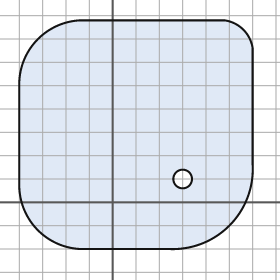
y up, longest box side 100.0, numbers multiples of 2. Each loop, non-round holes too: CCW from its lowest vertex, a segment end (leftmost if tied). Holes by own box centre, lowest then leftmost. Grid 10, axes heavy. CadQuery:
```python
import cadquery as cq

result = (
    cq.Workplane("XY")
    .moveTo(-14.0, -20.0)
    .lineTo(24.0, -20.0)
    .threePointArc((50.0, -10.0), (60.0, 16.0))
    .lineTo(60.0, 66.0)
    .threePointArc((56.0, 74.0), (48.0, 78.0))
    .lineTo(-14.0, 78.0)
    .threePointArc((-32.0, 70.0), (-40.0, 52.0))
    .lineTo(-40.0, 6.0)
    .threePointArc((-32.0, -12.0), (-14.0, -20.0))
    .close()
    .moveTo(30.0, 10.0)
    .circle(4.0)
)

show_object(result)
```